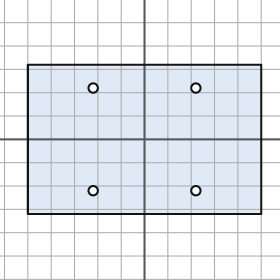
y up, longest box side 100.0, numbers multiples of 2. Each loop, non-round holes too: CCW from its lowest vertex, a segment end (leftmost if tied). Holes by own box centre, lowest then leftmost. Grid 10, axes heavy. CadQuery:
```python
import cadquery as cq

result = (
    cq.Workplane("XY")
    .moveTo(-50.0, -32.0)
    .lineTo(50.0, -32.0)
    .lineTo(50.0, 32.0)
    .lineTo(-50.0, 32.0)
    .close()
    .moveTo(-22.0, -22.0)
    .circle(2.0)
    .moveTo(22.0, -22.0)
    .circle(2.0)
    .moveTo(-22.0, 22.0)
    .circle(2.0)
    .moveTo(22.0, 22.0)
    .circle(2.0)
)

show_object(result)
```